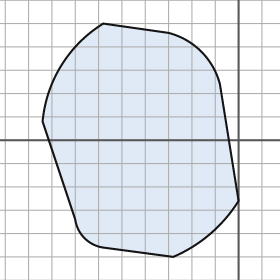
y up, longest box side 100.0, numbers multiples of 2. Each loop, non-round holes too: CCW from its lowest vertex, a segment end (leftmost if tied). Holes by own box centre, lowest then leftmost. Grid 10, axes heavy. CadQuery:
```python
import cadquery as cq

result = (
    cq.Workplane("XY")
    .moveTo(-28.0, -50.0)
    .threePointArc((-12.0, -40.0), (0.0, -26.0))
    .lineTo(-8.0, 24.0)
    .threePointArc((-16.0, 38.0), (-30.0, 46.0))
    .lineTo(-58.0, 50.0)
    .threePointArc((-76.0, 32.0), (-84.0, 8.0))
    .lineTo(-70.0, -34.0)
    .threePointArc((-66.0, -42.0), (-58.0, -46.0))
    .close()
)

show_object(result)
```